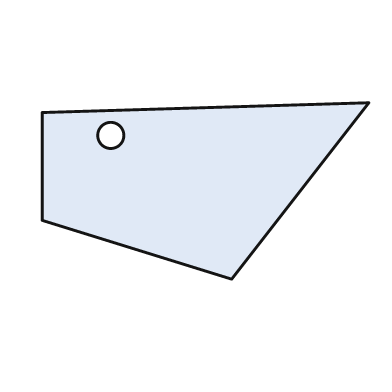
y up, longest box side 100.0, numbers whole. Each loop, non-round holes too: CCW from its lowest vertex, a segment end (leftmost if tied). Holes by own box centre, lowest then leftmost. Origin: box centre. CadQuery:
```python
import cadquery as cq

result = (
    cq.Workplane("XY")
    .moveTo(8.0, -27.0)
    .lineTo(50.0, 27.0)
    .lineTo(-50.0, 24.0)
    .lineTo(-50.0, -9.0)
    .close()
    .moveTo(-29.0, 17.0)
    .circle(4.0)
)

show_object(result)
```